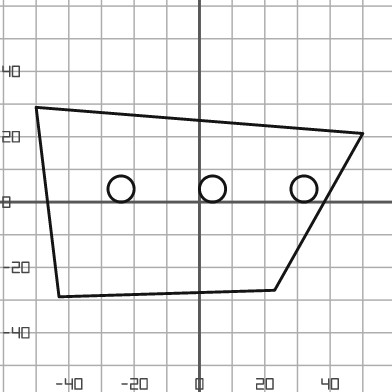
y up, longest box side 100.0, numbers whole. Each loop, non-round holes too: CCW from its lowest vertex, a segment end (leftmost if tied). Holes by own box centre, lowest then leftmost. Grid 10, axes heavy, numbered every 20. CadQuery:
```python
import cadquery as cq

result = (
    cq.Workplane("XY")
    .moveTo(-43.0, -29.0)
    .lineTo(23.0, -27.0)
    .lineTo(50.0, 21.0)
    .lineTo(-50.0, 29.0)
    .close()
    .moveTo(-24.0, 4.0)
    .circle(4.0)
    .moveTo(4.0, 4.0)
    .circle(4.0)
    .moveTo(32.0, 4.0)
    .circle(4.0)
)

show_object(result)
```